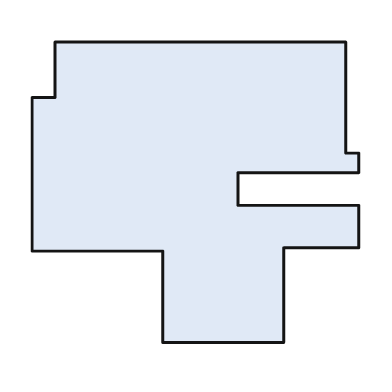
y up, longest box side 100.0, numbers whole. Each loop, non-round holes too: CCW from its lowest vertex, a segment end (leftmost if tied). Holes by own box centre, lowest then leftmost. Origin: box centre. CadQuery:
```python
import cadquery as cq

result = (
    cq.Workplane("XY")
    .moveTo(-10.0, -46.0)
    .lineTo(27.0, -46.0)
    .lineTo(27.0, -17.0)
    .lineTo(50.0, -17.0)
    .lineTo(50.0, -4.0)
    .lineTo(13.0, -4.0)
    .lineTo(13.0, 6.0)
    .lineTo(50.0, 6.0)
    .lineTo(50.0, 12.0)
    .lineTo(46.0, 12.0)
    .lineTo(46.0, 46.0)
    .lineTo(-43.0, 46.0)
    .lineTo(-43.0, 29.0)
    .lineTo(-50.0, 29.0)
    .lineTo(-50.0, -18.0)
    .lineTo(-10.0, -18.0)
    .close()
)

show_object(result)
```